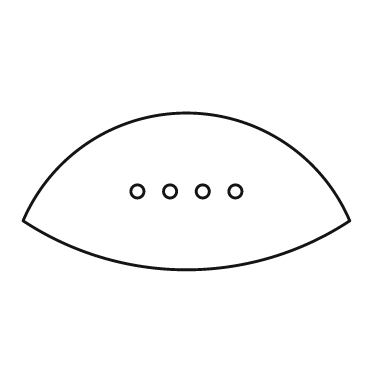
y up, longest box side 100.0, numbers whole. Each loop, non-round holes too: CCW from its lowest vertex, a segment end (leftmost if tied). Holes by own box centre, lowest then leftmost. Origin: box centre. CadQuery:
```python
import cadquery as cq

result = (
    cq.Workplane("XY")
    .moveTo(-50.0, -9.0)
    .threePointArc((0.0, -24.0), (50.0, -9.0))
    .threePointArc((0.0, 24.0), (-50.0, -9.0))
    .close()
    .moveTo(-15.0, 0.0)
    .circle(2.0)
    .moveTo(-5.0, 0.0)
    .circle(2.0)
    .moveTo(5.0, 0.0)
    .circle(2.0)
    .moveTo(15.0, 0.0)
    .circle(2.0)
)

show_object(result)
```